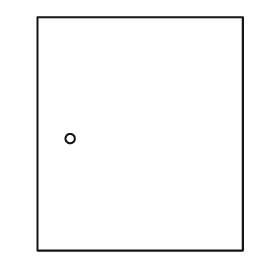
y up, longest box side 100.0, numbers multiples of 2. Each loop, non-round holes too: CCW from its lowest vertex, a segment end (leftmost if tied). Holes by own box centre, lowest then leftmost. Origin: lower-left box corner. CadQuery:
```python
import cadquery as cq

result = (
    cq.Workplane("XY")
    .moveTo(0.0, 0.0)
    .lineTo(88.0, 0.0)
    .lineTo(88.0, 100.0)
    .lineTo(0.0, 100.0)
    .close()
    .moveTo(14.0, 48.0)
    .circle(2.0)
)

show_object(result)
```